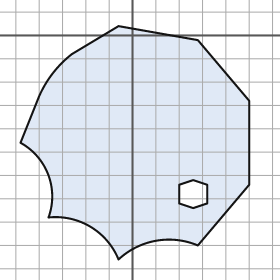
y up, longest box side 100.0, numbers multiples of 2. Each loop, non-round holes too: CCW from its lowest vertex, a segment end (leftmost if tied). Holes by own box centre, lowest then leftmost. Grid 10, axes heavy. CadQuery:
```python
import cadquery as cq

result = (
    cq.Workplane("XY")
    .moveTo(-6.0, -96.0)
    .threePointArc((10.0, -88.0), (28.0, -90.0))
    .lineTo(50.0, -64.0)
    .lineTo(50.0, -28.0)
    .lineTo(28.0, -2.0)
    .lineTo(-6.0, 4.0)
    .lineTo(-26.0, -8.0)
    .threePointArc((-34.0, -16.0), (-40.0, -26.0))
    .lineTo(-48.0, -46.0)
    .threePointArc((-36.0, -60.0), (-36.0, -78.0))
    .threePointArc((-18.0, -82.0), (-6.0, -96.0))
    .close()
    .moveTo(26.0, -74.0)
    .lineTo(32.0, -72.0)
    .lineTo(32.0, -64.0)
    .lineTo(26.0, -62.0)
    .lineTo(20.0, -64.0)
    .lineTo(20.0, -72.0)
    .close()
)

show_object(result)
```